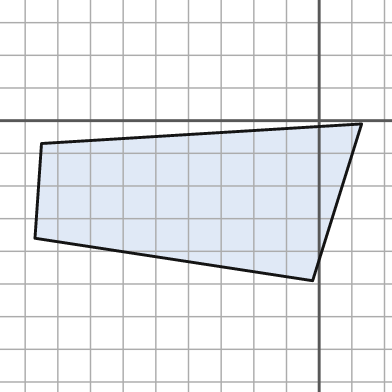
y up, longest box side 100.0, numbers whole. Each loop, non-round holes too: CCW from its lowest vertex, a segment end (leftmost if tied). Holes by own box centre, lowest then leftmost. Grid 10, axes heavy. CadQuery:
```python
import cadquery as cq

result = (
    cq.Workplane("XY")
    .moveTo(-2.0, -49.0)
    .lineTo(13.0, -1.0)
    .lineTo(-85.0, -7.0)
    .lineTo(-87.0, -36.0)
    .close()
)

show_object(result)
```